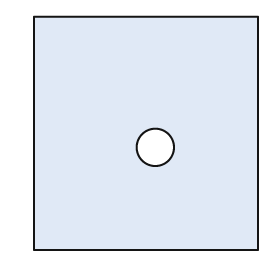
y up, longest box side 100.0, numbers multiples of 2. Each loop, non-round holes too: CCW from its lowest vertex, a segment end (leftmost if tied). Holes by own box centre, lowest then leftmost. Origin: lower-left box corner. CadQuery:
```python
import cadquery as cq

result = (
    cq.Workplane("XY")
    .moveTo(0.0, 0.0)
    .lineTo(96.0, 0.0)
    .lineTo(96.0, 100.0)
    .lineTo(0.0, 100.0)
    .close()
    .moveTo(52.0, 44.0)
    .circle(8.0)
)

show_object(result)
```